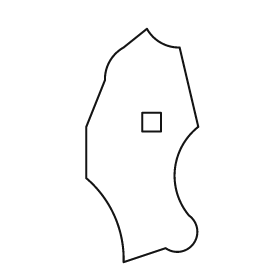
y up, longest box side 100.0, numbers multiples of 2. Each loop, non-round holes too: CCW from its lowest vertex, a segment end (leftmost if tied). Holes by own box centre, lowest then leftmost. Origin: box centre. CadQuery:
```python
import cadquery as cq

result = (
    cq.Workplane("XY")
    .moveTo(-8.0, -50.0)
    .lineTo(10.0, -44.0)
    .threePointArc((22.0, -42.0), (20.0, -30.0))
    .threePointArc((14.0, -10.0), (24.0, 8.0))
    .lineTo(16.0, 42.0)
    .threePointArc((8.0, 44.0), (2.0, 50.0))
    .lineTo(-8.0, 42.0)
    .threePointArc((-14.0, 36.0), (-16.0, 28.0))
    .lineTo(-24.0, 8.0)
    .lineTo(-24.0, -14.0)
    .threePointArc((-12.0, -30.0), (-8.0, -50.0))
    .close()
    .moveTo(0.0, 6.0)
    .lineTo(8.0, 6.0)
    .lineTo(8.0, 14.0)
    .lineTo(0.0, 14.0)
    .close()
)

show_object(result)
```